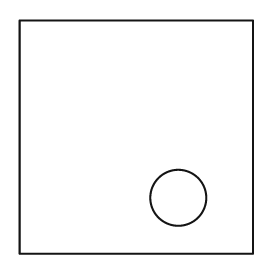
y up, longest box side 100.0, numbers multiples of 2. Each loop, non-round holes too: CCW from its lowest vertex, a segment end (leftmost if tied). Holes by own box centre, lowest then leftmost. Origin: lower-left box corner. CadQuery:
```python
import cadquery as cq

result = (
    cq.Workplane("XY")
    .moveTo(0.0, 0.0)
    .lineTo(100.0, 0.0)
    .lineTo(100.0, 100.0)
    .lineTo(0.0, 100.0)
    .close()
    .moveTo(68.0, 24.0)
    .circle(12.0)
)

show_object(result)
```